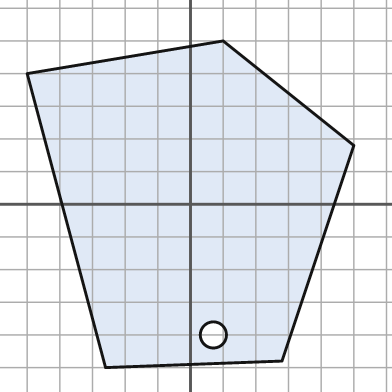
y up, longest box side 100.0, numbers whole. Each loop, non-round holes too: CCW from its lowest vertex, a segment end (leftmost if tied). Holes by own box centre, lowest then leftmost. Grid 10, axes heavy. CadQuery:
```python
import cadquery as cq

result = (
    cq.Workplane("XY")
    .moveTo(-26.0, -50.0)
    .lineTo(28.0, -48.0)
    .lineTo(50.0, 18.0)
    .lineTo(10.0, 50.0)
    .lineTo(-50.0, 40.0)
    .close()
    .moveTo(7.0, -40.0)
    .circle(4.0)
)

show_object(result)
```